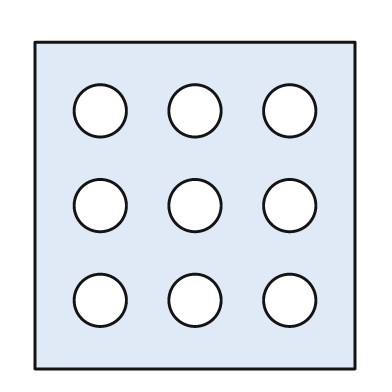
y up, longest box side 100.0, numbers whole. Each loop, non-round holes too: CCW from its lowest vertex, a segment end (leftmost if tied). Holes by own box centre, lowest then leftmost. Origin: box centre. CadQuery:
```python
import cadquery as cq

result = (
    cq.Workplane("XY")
    .moveTo(-49.0, -50.0)
    .lineTo(49.0, -50.0)
    .lineTo(49.0, 50.0)
    .lineTo(-49.0, 50.0)
    .close()
    .moveTo(-29.0, -29.0)
    .circle(8.0)
    .moveTo(0.0, -29.0)
    .circle(8.0)
    .moveTo(29.0, -29.0)
    .circle(8.0)
    .moveTo(-29.0, 0.0)
    .circle(8.0)
    .moveTo(0.0, 0.0)
    .circle(8.0)
    .moveTo(29.0, 0.0)
    .circle(8.0)
    .moveTo(-29.0, 29.0)
    .circle(8.0)
    .moveTo(0.0, 29.0)
    .circle(8.0)
    .moveTo(29.0, 29.0)
    .circle(8.0)
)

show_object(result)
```